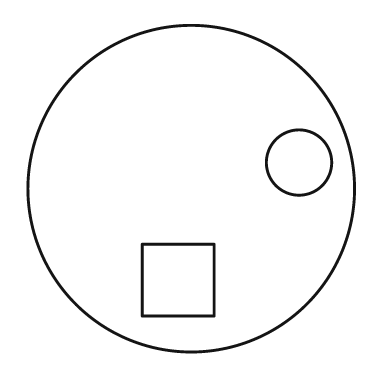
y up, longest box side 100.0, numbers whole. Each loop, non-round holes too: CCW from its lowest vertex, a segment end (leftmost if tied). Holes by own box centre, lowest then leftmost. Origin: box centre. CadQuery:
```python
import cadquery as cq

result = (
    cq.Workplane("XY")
    .moveTo(0.0, 0.0)
    .circle(50.0)
    .moveTo(-15.0, -39.0)
    .lineTo(7.0, -39.0)
    .lineTo(7.0, -17.0)
    .lineTo(-15.0, -17.0)
    .close()
    .moveTo(33.0, 8.0)
    .circle(10.0)
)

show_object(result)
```